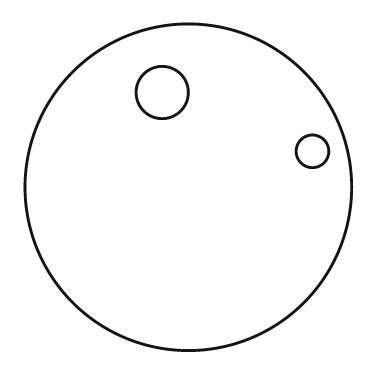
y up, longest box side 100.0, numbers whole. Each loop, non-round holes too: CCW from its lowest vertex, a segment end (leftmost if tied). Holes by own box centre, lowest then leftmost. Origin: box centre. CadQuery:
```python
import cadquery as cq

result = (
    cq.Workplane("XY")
    .moveTo(0.0, 0.0)
    .circle(50.0)
    .moveTo(38.0, 11.0)
    .circle(5.0)
    .moveTo(-8.0, 29.0)
    .circle(8.0)
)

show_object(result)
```